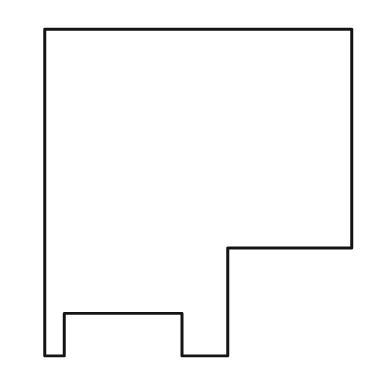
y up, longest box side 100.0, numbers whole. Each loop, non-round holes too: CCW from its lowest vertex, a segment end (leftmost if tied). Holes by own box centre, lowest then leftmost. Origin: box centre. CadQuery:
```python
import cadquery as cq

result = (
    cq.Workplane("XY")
    .moveTo(-47.0, -50.0)
    .lineTo(-41.0, -50.0)
    .lineTo(-41.0, -37.0)
    .lineTo(-5.0, -37.0)
    .lineTo(-5.0, -50.0)
    .lineTo(9.0, -50.0)
    .lineTo(9.0, -17.0)
    .lineTo(47.0, -17.0)
    .lineTo(47.0, 50.0)
    .lineTo(-47.0, 50.0)
    .close()
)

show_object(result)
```